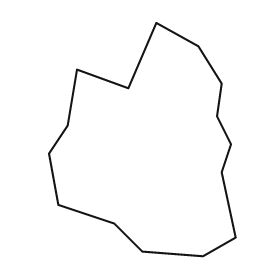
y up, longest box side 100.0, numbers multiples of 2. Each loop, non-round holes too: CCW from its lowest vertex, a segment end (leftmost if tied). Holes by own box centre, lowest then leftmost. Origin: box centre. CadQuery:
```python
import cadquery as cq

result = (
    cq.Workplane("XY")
    .moveTo(26.0, -50.0)
    .lineTo(40.0, -42.0)
    .lineTo(34.0, -14.0)
    .lineTo(38.0, -2.0)
    .lineTo(32.0, 10.0)
    .lineTo(34.0, 24.0)
    .lineTo(24.0, 40.0)
    .lineTo(6.0, 50.0)
    .lineTo(-6.0, 22.0)
    .lineTo(-28.0, 30.0)
    .lineTo(-32.0, 6.0)
    .lineTo(-40.0, -6.0)
    .lineTo(-36.0, -28.0)
    .lineTo(-12.0, -36.0)
    .lineTo(0.0, -48.0)
    .close()
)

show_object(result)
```